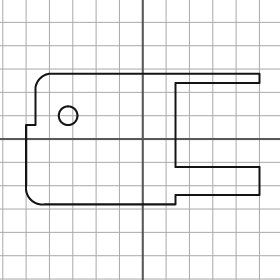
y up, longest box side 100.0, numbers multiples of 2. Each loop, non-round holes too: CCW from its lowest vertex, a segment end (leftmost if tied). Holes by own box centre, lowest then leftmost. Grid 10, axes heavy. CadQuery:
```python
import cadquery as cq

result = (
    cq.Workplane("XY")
    .moveTo(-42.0, -28.0)
    .lineTo(14.0, -28.0)
    .lineTo(14.0, -24.0)
    .lineTo(50.0, -24.0)
    .lineTo(50.0, -12.0)
    .lineTo(14.0, -12.0)
    .lineTo(14.0, 24.0)
    .lineTo(50.0, 24.0)
    .lineTo(50.0, 28.0)
    .lineTo(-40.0, 28.0)
    .threePointArc((-44.0, 26.0), (-46.0, 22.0))
    .lineTo(-46.0, 6.0)
    .lineTo(-50.0, 6.0)
    .lineTo(-50.0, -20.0)
    .threePointArc((-48.0, -26.0), (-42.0, -28.0))
    .close()
    .moveTo(-32.0, 10.0)
    .circle(4.0)
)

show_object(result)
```